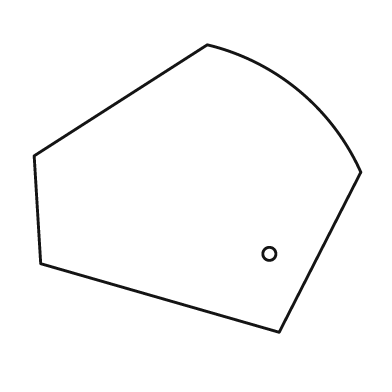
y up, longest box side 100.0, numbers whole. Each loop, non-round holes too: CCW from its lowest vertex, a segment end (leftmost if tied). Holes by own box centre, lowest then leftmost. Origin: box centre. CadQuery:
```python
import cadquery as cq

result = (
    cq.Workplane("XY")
    .moveTo(25.0, -44.0)
    .lineTo(50.0, 5.0)
    .threePointArc((31.0, 30.0), (3.0, 44.0))
    .lineTo(-50.0, 10.0)
    .lineTo(-48.0, -23.0)
    .close()
    .moveTo(22.0, -20.0)
    .circle(2.0)
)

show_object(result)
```